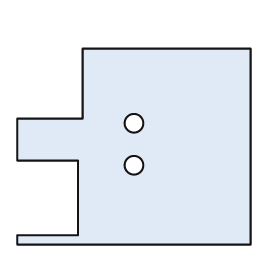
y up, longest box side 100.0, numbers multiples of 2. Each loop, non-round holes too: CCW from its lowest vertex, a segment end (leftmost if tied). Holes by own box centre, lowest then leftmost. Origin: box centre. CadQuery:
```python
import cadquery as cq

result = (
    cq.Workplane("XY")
    .moveTo(-50.0, -42.0)
    .lineTo(50.0, -42.0)
    .lineTo(50.0, 42.0)
    .lineTo(-22.0, 42.0)
    .lineTo(-22.0, 12.0)
    .lineTo(-50.0, 12.0)
    .lineTo(-50.0, -6.0)
    .lineTo(-24.0, -6.0)
    .lineTo(-24.0, -38.0)
    .lineTo(-50.0, -38.0)
    .close()
    .moveTo(0.0, -8.0)
    .circle(4.0)
    .moveTo(0.0, 10.0)
    .circle(4.0)
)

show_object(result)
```